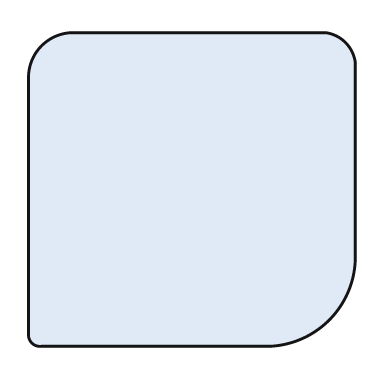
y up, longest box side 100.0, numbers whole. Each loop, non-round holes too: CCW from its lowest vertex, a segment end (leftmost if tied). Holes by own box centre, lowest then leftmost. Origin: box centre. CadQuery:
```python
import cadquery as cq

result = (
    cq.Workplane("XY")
    .moveTo(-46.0, -48.0)
    .lineTo(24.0, -48.0)
    .threePointArc((42.0, -40.0), (50.0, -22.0))
    .lineTo(50.0, 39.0)
    .threePointArc((47.0, 45.0), (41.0, 48.0))
    .lineTo(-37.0, 48.0)
    .threePointArc((-46.0, 44.0), (-50.0, 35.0))
    .lineTo(-50.0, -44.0)
    .threePointArc((-49.0, -47.0), (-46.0, -48.0))
    .close()
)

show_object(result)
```